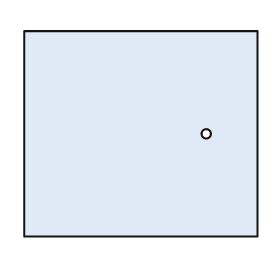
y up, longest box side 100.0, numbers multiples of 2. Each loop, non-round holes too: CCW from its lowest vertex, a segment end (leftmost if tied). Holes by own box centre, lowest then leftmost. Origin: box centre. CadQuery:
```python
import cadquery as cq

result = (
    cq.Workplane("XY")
    .moveTo(-50.0, -44.0)
    .lineTo(50.0, -44.0)
    .lineTo(50.0, 44.0)
    .lineTo(-50.0, 44.0)
    .close()
    .moveTo(28.0, 0.0)
    .circle(2.0)
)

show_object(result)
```